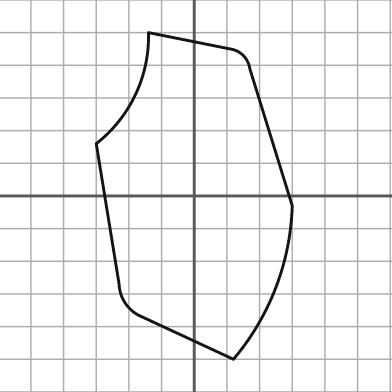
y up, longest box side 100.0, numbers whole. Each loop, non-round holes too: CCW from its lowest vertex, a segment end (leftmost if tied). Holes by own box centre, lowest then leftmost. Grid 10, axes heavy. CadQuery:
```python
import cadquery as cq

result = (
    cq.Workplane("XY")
    .moveTo(12.0, -50.0)
    .threePointArc((25.0, -28.0), (30.0, -3.0))
    .lineTo(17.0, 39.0)
    .threePointArc((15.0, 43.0), (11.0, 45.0))
    .lineTo(-14.0, 50.0)
    .threePointArc((-18.0, 31.0), (-30.0, 16.0))
    .lineTo(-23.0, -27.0)
    .threePointArc((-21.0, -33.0), (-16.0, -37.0))
    .close()
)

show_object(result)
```